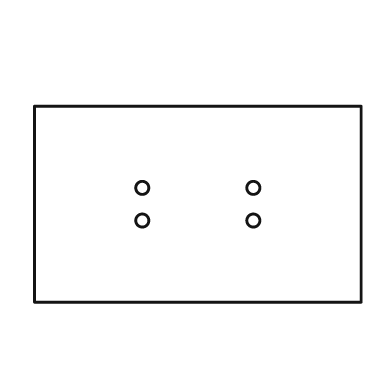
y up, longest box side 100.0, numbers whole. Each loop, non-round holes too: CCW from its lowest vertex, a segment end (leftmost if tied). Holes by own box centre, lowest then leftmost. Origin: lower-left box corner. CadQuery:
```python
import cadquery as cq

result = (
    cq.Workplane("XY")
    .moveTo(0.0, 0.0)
    .lineTo(100.0, 0.0)
    .lineTo(100.0, 60.0)
    .lineTo(0.0, 60.0)
    .close()
    .moveTo(33.0, 25.0)
    .circle(2.0)
    .moveTo(67.0, 25.0)
    .circle(2.0)
    .moveTo(33.0, 35.0)
    .circle(2.0)
    .moveTo(67.0, 35.0)
    .circle(2.0)
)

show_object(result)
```